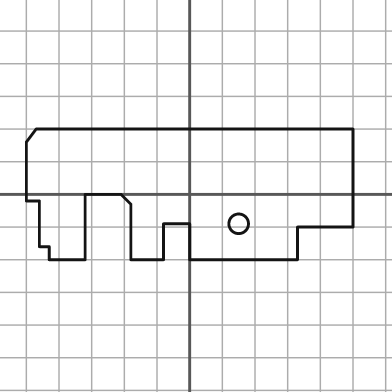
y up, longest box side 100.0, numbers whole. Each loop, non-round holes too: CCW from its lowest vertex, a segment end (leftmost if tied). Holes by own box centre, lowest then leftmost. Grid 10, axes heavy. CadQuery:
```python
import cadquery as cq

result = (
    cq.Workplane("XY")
    .moveTo(-43.0, -20.0)
    .lineTo(-32.0, -20.0)
    .lineTo(-32.0, 0.0)
    .lineTo(-21.0, 0.0)
    .lineTo(-18.0, -3.0)
    .lineTo(-18.0, -20.0)
    .lineTo(-8.0, -20.0)
    .lineTo(-8.0, -9.0)
    .lineTo(0.0, -9.0)
    .lineTo(0.0, -20.0)
    .lineTo(33.0, -20.0)
    .lineTo(33.0, -10.0)
    .lineTo(50.0, -10.0)
    .lineTo(50.0, 20.0)
    .lineTo(-47.0, 20.0)
    .lineTo(-50.0, 16.0)
    .lineTo(-50.0, -2.0)
    .lineTo(-46.0, -2.0)
    .lineTo(-46.0, -16.0)
    .lineTo(-43.0, -16.0)
    .close()
    .moveTo(15.0, -9.0)
    .circle(3.0)
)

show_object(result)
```